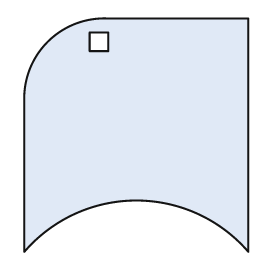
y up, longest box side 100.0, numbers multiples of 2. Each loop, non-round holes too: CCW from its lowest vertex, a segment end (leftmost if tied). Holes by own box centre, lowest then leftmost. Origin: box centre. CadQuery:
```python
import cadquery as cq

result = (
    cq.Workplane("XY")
    .moveTo(-48.0, -50.0)
    .threePointArc((0.0, -28.0), (48.0, -50.0))
    .lineTo(48.0, 50.0)
    .lineTo(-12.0, 50.0)
    .threePointArc((-38.0, 40.0), (-48.0, 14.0))
    .close()
    .moveTo(-20.0, 36.0)
    .lineTo(-12.0, 36.0)
    .lineTo(-12.0, 44.0)
    .lineTo(-20.0, 44.0)
    .close()
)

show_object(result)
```